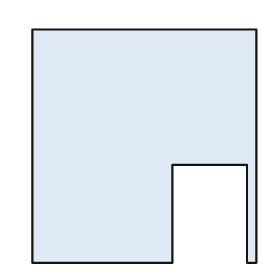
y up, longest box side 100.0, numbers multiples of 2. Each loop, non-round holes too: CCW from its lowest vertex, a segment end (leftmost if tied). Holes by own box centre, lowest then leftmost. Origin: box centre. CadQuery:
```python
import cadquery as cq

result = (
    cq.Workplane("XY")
    .moveTo(-48.0, -50.0)
    .lineTo(12.0, -50.0)
    .lineTo(12.0, -8.0)
    .lineTo(44.0, -8.0)
    .lineTo(44.0, -50.0)
    .lineTo(48.0, -50.0)
    .lineTo(48.0, 50.0)
    .lineTo(-48.0, 50.0)
    .close()
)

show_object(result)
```